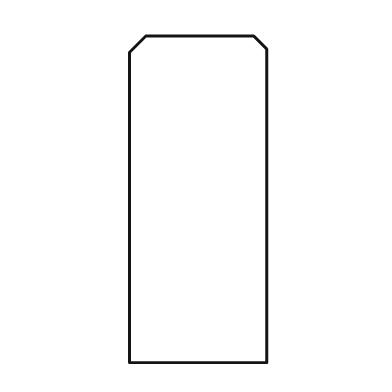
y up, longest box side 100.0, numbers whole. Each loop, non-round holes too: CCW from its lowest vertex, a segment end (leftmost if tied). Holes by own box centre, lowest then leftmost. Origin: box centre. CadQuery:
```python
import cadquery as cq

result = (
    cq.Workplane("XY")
    .moveTo(-21.0, -50.0)
    .lineTo(21.0, -50.0)
    .lineTo(21.0, 46.0)
    .lineTo(17.0, 50.0)
    .lineTo(-16.0, 50.0)
    .lineTo(-21.0, 45.0)
    .close()
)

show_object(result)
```